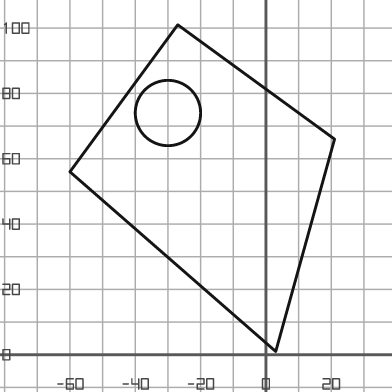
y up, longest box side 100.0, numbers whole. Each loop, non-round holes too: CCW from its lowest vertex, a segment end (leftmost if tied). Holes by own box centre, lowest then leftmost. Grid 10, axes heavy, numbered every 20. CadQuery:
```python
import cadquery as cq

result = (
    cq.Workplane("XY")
    .moveTo(3.0, 1.0)
    .lineTo(21.0, 66.0)
    .lineTo(-27.0, 101.0)
    .lineTo(-60.0, 56.0)
    .close()
    .moveTo(-30.0, 74.0)
    .circle(10.0)
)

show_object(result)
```